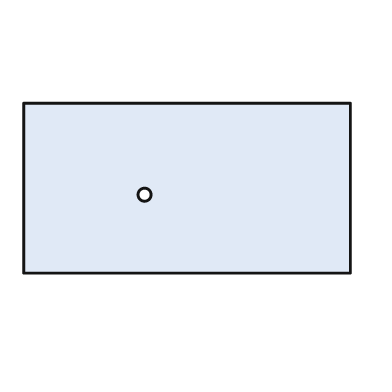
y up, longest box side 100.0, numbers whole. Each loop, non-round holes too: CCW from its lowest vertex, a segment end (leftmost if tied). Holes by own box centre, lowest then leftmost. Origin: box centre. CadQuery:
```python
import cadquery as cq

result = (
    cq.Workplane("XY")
    .moveTo(-50.0, -26.0)
    .lineTo(50.0, -26.0)
    .lineTo(50.0, 26.0)
    .lineTo(-50.0, 26.0)
    .close()
    .moveTo(-13.0, -2.0)
    .circle(2.0)
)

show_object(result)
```